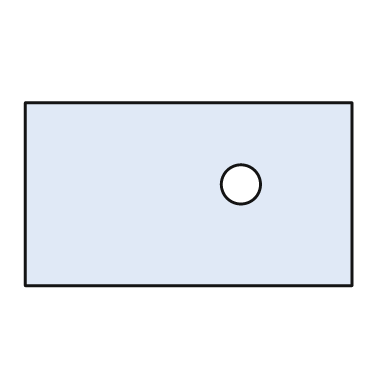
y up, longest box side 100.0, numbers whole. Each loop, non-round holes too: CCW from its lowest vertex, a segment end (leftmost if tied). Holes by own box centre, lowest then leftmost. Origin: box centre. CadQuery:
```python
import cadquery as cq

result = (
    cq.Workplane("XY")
    .moveTo(-50.0, -28.0)
    .lineTo(50.0, -28.0)
    .lineTo(50.0, 28.0)
    .lineTo(-50.0, 28.0)
    .close()
    .moveTo(16.0, 3.0)
    .circle(6.0)
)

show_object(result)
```